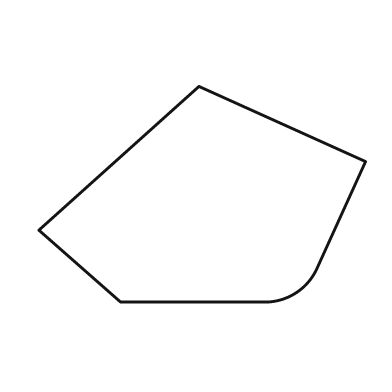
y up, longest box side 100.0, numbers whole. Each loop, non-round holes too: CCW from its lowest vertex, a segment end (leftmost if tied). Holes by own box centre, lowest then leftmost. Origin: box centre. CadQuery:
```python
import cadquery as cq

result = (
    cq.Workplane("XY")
    .moveTo(-25.0, -33.0)
    .lineTo(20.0, -33.0)
    .threePointArc((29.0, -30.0), (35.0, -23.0))
    .lineTo(50.0, 10.0)
    .lineTo(-1.0, 33.0)
    .lineTo(-50.0, -11.0)
    .close()
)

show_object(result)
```